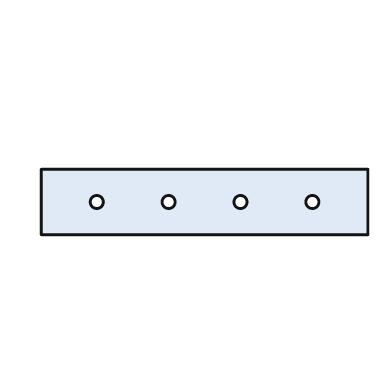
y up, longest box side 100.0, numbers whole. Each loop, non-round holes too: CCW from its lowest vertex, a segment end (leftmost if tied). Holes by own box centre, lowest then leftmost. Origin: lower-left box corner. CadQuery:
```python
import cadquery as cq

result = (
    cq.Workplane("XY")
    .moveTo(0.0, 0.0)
    .lineTo(100.0, 0.0)
    .lineTo(100.0, 20.0)
    .lineTo(0.0, 20.0)
    .close()
    .moveTo(17.0, 10.0)
    .circle(2.0)
    .moveTo(39.0, 10.0)
    .circle(2.0)
    .moveTo(61.0, 10.0)
    .circle(2.0)
    .moveTo(83.0, 10.0)
    .circle(2.0)
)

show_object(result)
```